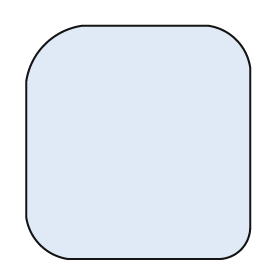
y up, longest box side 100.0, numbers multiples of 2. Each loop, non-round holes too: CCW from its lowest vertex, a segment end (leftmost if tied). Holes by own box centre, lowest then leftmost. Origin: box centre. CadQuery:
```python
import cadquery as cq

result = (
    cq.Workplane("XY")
    .moveTo(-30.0, -50.0)
    .lineTo(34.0, -50.0)
    .threePointArc((44.0, -46.0), (48.0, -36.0))
    .lineTo(48.0, 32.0)
    .threePointArc((42.0, 44.0), (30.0, 50.0))
    .lineTo(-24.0, 50.0)
    .threePointArc((-40.0, 42.0), (-48.0, 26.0))
    .lineTo(-48.0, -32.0)
    .threePointArc((-42.0, -44.0), (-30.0, -50.0))
    .close()
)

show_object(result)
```